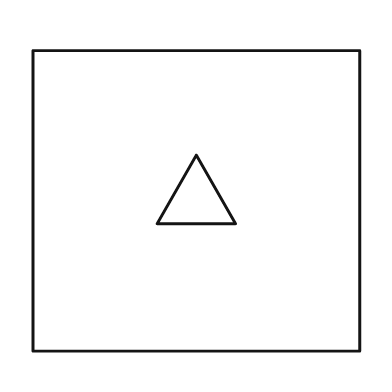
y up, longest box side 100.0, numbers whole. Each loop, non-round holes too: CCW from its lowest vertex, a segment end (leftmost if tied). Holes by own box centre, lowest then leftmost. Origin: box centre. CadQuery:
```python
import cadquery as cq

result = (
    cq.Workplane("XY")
    .moveTo(-50.0, -46.0)
    .lineTo(50.0, -46.0)
    .lineTo(50.0, 46.0)
    .lineTo(-50.0, 46.0)
    .close()
    .moveTo(-12.0, -7.0)
    .lineTo(12.0, -7.0)
    .lineTo(0.0, 14.0)
    .close()
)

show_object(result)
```